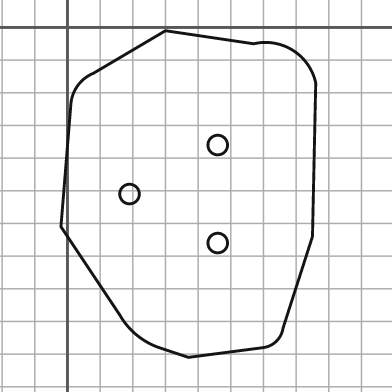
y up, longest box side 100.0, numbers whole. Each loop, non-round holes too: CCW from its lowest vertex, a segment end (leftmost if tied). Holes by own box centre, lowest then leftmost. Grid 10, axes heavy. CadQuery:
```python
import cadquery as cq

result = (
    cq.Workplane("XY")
    .moveTo(37.0, -101.0)
    .lineTo(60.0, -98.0)
    .threePointArc((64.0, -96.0), (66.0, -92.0))
    .lineTo(75.0, -64.0)
    .lineTo(76.0, -17.0)
    .threePointArc((69.0, -7.0), (57.0, -5.0))
    .lineTo(30.0, -1.0)
    .lineTo(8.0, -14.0)
    .threePointArc((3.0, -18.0), (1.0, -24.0))
    .lineTo(-2.0, -61.0)
    .lineTo(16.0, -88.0)
    .threePointArc((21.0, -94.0), (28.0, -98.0))
    .close()
    .moveTo(46.0, -66.0)
    .circle(3.0)
    .moveTo(19.0, -51.0)
    .circle(3.0)
    .moveTo(46.0, -36.0)
    .circle(3.0)
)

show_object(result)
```